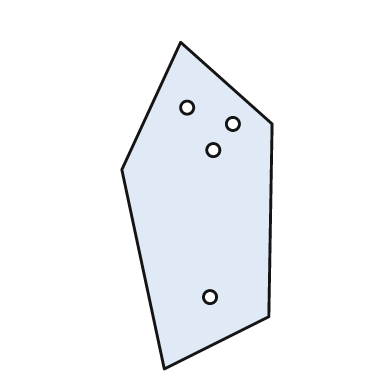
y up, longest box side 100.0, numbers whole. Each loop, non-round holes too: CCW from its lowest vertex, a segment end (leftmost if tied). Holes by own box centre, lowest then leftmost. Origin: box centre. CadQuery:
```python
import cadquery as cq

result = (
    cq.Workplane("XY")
    .moveTo(-10.0, -50.0)
    .lineTo(22.0, -34.0)
    .lineTo(23.0, 25.0)
    .lineTo(-5.0, 50.0)
    .lineTo(-23.0, 11.0)
    .close()
    .moveTo(4.0, -28.0)
    .circle(2.0)
    .moveTo(5.0, 17.0)
    .circle(2.0)
    .moveTo(11.0, 25.0)
    .circle(2.0)
    .moveTo(-3.0, 30.0)
    .circle(2.0)
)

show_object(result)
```